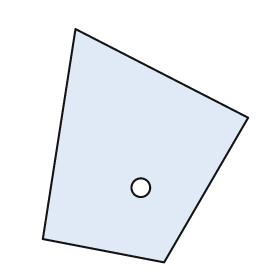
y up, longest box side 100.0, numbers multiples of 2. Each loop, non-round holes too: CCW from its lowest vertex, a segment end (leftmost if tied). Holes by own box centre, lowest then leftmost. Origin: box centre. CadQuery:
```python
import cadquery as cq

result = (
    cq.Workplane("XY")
    .moveTo(8.0, -50.0)
    .lineTo(44.0, 12.0)
    .lineTo(-30.0, 50.0)
    .lineTo(-44.0, -40.0)
    .close()
    .moveTo(-2.0, -18.0)
    .circle(4.0)
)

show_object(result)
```